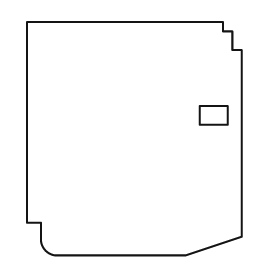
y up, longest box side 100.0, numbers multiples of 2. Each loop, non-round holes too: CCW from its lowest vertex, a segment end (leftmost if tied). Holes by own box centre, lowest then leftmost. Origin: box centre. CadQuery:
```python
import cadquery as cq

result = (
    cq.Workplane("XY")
    .moveTo(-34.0, -50.0)
    .lineTo(22.0, -50.0)
    .lineTo(46.0, -42.0)
    .lineTo(46.0, 38.0)
    .lineTo(42.0, 38.0)
    .lineTo(42.0, 46.0)
    .lineTo(38.0, 46.0)
    .lineTo(38.0, 50.0)
    .lineTo(-46.0, 50.0)
    .lineTo(-46.0, -36.0)
    .lineTo(-40.0, -36.0)
    .lineTo(-40.0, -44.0)
    .threePointArc((-38.0, -48.0), (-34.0, -50.0))
    .close()
    .moveTo(28.0, 6.0)
    .lineTo(40.0, 6.0)
    .lineTo(40.0, 14.0)
    .lineTo(28.0, 14.0)
    .close()
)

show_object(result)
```